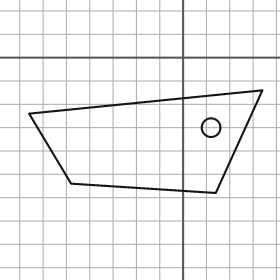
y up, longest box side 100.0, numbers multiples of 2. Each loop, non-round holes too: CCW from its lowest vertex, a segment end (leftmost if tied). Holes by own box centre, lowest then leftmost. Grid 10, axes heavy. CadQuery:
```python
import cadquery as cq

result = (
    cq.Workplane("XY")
    .moveTo(14.0, -58.0)
    .lineTo(34.0, -14.0)
    .lineTo(-66.0, -24.0)
    .lineTo(-48.0, -54.0)
    .close()
    .moveTo(12.0, -30.0)
    .circle(4.0)
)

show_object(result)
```